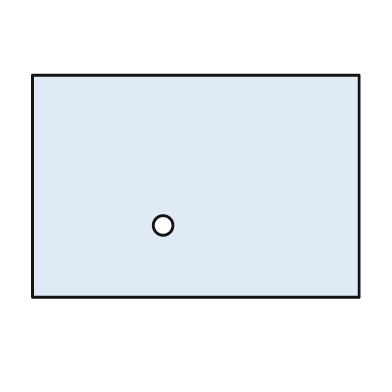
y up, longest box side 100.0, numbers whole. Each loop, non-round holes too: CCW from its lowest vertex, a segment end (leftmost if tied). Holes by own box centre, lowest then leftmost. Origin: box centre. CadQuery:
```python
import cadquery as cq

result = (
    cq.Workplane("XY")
    .moveTo(-50.0, -34.0)
    .lineTo(50.0, -34.0)
    .lineTo(50.0, 34.0)
    .lineTo(-50.0, 34.0)
    .close()
    .moveTo(-10.0, -12.0)
    .circle(3.0)
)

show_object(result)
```